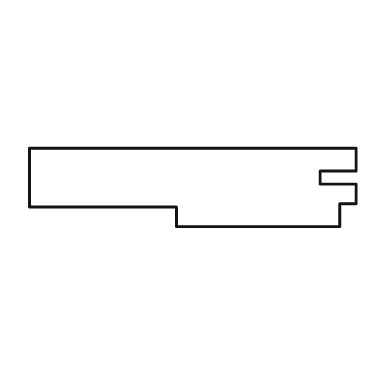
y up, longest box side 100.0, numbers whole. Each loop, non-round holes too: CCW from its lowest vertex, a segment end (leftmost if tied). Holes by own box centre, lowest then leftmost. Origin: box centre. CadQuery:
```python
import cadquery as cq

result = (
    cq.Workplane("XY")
    .moveTo(-5.0, -12.0)
    .lineTo(45.0, -12.0)
    .lineTo(45.0, -5.0)
    .lineTo(50.0, -5.0)
    .lineTo(50.0, 1.0)
    .lineTo(39.0, 1.0)
    .lineTo(39.0, 5.0)
    .lineTo(50.0, 5.0)
    .lineTo(50.0, 12.0)
    .lineTo(-50.0, 12.0)
    .lineTo(-50.0, -6.0)
    .lineTo(-5.0, -6.0)
    .close()
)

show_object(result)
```